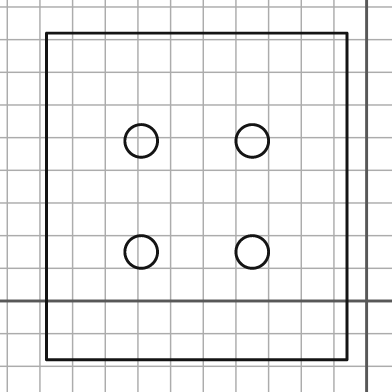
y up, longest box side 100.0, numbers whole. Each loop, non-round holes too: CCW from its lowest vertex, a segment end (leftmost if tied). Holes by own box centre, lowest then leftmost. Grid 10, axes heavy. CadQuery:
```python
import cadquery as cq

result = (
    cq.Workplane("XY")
    .moveTo(-98.0, -18.0)
    .lineTo(-6.0, -18.0)
    .lineTo(-6.0, 82.0)
    .lineTo(-98.0, 82.0)
    .close()
    .moveTo(-69.0, 15.0)
    .circle(5.0)
    .moveTo(-35.0, 15.0)
    .circle(5.0)
    .moveTo(-69.0, 49.0)
    .circle(5.0)
    .moveTo(-35.0, 49.0)
    .circle(5.0)
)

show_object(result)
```